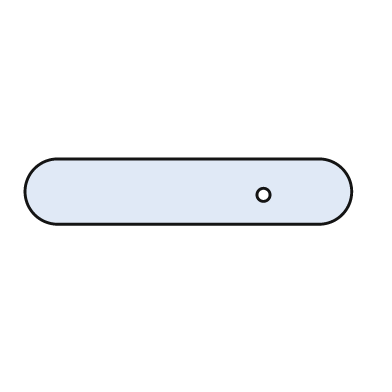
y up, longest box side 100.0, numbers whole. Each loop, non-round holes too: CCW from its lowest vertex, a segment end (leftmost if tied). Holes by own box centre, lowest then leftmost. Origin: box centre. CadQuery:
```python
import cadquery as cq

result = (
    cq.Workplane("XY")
    .moveTo(-40.0, -10.0)
    .lineTo(40.0, -10.0)
    .threePointArc((50.0, 0.0), (40.0, 10.0))
    .lineTo(-40.0, 10.0)
    .threePointArc((-50.0, 0.0), (-40.0, -10.0))
    .close()
    .moveTo(23.0, -1.0)
    .circle(2.0)
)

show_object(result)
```